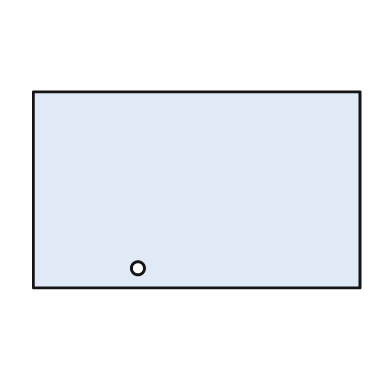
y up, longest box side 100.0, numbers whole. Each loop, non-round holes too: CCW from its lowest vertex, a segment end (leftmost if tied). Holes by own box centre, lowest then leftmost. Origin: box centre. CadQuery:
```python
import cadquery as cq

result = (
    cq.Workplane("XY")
    .moveTo(-50.0, -30.0)
    .lineTo(50.0, -30.0)
    .lineTo(50.0, 30.0)
    .lineTo(-50.0, 30.0)
    .close()
    .moveTo(-18.0, -24.0)
    .circle(2.0)
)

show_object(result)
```